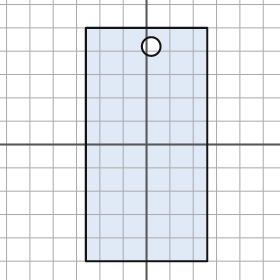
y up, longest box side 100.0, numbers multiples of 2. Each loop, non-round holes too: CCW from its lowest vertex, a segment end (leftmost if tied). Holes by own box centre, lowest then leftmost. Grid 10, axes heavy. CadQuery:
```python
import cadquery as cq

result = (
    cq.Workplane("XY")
    .moveTo(-26.0, -50.0)
    .lineTo(26.0, -50.0)
    .lineTo(26.0, 50.0)
    .lineTo(-26.0, 50.0)
    .close()
    .moveTo(2.0, 42.0)
    .circle(4.0)
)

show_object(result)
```